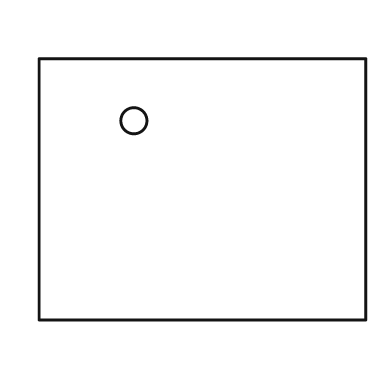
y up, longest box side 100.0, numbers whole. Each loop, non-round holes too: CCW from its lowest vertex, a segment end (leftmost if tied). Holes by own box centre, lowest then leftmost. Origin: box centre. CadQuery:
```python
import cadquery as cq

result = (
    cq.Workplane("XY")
    .moveTo(-50.0, -40.0)
    .lineTo(50.0, -40.0)
    .lineTo(50.0, 40.0)
    .lineTo(-50.0, 40.0)
    .close()
    .moveTo(-21.0, 21.0)
    .circle(4.0)
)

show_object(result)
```